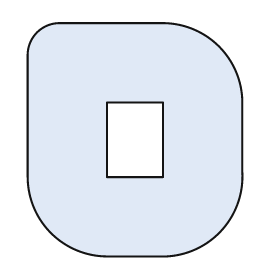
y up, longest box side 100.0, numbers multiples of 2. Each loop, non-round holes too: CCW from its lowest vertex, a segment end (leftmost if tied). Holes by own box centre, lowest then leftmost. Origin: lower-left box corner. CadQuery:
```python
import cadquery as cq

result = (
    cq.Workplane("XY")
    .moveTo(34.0, 0.0)
    .lineTo(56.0, 0.0)
    .threePointArc((82.0, 10.0), (92.0, 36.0))
    .lineTo(92.0, 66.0)
    .threePointArc((82.0, 90.0), (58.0, 100.0))
    .lineTo(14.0, 100.0)
    .threePointArc((4.0, 96.0), (0.0, 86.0))
    .lineTo(0.0, 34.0)
    .threePointArc((10.0, 10.0), (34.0, 0.0))
    .close()
    .moveTo(34.0, 34.0)
    .lineTo(58.0, 34.0)
    .lineTo(58.0, 66.0)
    .lineTo(34.0, 66.0)
    .close()
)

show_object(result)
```